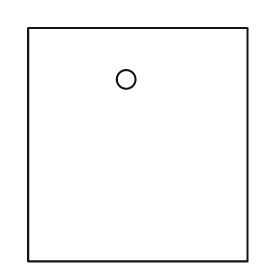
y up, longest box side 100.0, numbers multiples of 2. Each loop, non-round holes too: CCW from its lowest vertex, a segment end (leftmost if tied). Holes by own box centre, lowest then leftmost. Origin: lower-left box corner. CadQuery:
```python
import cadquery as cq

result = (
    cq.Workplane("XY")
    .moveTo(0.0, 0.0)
    .lineTo(94.0, 0.0)
    .lineTo(94.0, 100.0)
    .lineTo(0.0, 100.0)
    .close()
    .moveTo(42.0, 78.0)
    .circle(4.0)
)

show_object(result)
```